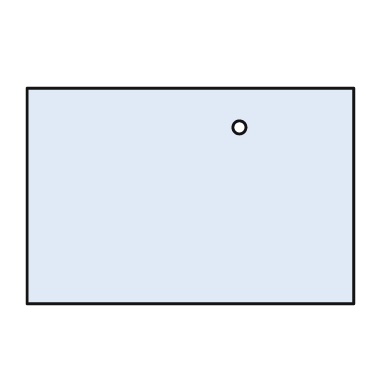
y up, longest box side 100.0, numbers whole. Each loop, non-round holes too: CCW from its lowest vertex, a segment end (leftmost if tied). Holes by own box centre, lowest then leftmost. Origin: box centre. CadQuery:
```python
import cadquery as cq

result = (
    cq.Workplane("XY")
    .moveTo(-50.0, -33.0)
    .lineTo(50.0, -33.0)
    .lineTo(50.0, 33.0)
    .lineTo(-50.0, 33.0)
    .close()
    .moveTo(15.0, 21.0)
    .circle(2.0)
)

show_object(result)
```